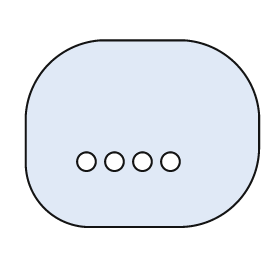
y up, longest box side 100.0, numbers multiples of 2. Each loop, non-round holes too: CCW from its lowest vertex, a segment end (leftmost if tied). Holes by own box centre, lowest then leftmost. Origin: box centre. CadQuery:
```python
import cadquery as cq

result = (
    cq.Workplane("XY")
    .moveTo(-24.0, -40.0)
    .lineTo(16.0, -40.0)
    .threePointArc((40.0, -30.0), (50.0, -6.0))
    .lineTo(50.0, 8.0)
    .threePointArc((40.0, 30.0), (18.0, 40.0))
    .lineTo(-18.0, 40.0)
    .threePointArc((-40.0, 30.0), (-50.0, 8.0))
    .lineTo(-50.0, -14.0)
    .threePointArc((-42.0, -32.0), (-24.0, -40.0))
    .close()
    .moveTo(-24.0, -12.0)
    .circle(4.0)
    .moveTo(-12.0, -12.0)
    .circle(4.0)
    .moveTo(0.0, -12.0)
    .circle(4.0)
    .moveTo(12.0, -12.0)
    .circle(4.0)
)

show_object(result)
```